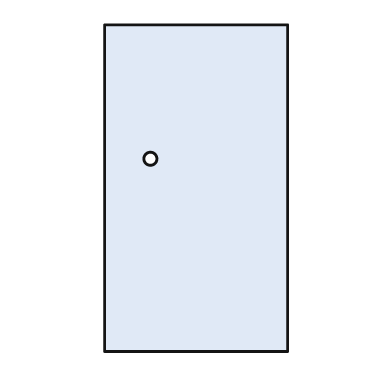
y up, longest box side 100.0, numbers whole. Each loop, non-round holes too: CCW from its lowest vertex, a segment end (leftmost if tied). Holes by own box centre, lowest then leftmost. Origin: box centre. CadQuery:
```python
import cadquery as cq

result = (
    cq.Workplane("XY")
    .moveTo(-28.0, -50.0)
    .lineTo(28.0, -50.0)
    .lineTo(28.0, 50.0)
    .lineTo(-28.0, 50.0)
    .close()
    .moveTo(-14.0, 9.0)
    .circle(2.0)
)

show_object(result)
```